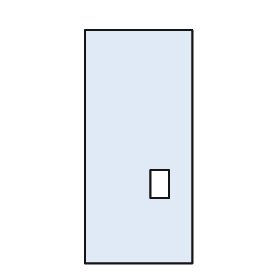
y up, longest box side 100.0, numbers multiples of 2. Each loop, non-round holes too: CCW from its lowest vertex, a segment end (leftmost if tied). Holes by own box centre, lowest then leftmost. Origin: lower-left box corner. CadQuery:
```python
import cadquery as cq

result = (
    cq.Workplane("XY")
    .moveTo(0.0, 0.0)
    .lineTo(46.0, 0.0)
    .lineTo(46.0, 100.0)
    .lineTo(0.0, 100.0)
    .close()
    .moveTo(28.0, 28.0)
    .lineTo(36.0, 28.0)
    .lineTo(36.0, 40.0)
    .lineTo(28.0, 40.0)
    .close()
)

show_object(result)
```